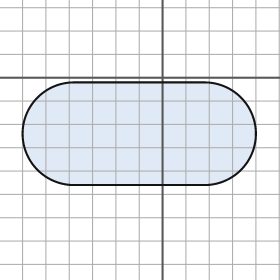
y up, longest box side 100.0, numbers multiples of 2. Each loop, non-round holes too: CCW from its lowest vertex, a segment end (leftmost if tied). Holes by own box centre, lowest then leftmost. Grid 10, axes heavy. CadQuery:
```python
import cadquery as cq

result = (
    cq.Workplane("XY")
    .moveTo(-38.0, -46.0)
    .lineTo(18.0, -46.0)
    .threePointArc((40.0, -24.0), (18.0, -2.0))
    .lineTo(-38.0, -2.0)
    .threePointArc((-60.0, -24.0), (-38.0, -46.0))
    .close()
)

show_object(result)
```